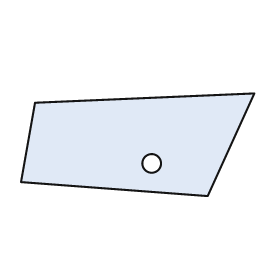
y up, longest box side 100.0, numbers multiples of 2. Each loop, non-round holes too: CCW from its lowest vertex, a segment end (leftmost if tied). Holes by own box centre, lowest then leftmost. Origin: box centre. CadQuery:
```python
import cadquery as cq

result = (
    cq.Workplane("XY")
    .moveTo(30.0, -22.0)
    .lineTo(50.0, 22.0)
    .lineTo(-44.0, 18.0)
    .lineTo(-50.0, -16.0)
    .close()
    .moveTo(6.0, -8.0)
    .circle(4.0)
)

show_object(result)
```